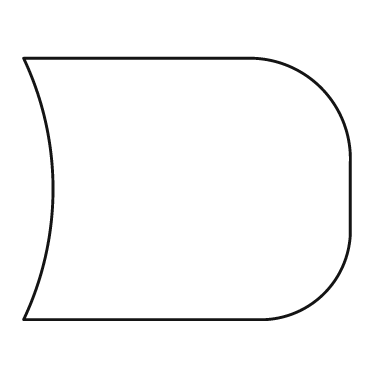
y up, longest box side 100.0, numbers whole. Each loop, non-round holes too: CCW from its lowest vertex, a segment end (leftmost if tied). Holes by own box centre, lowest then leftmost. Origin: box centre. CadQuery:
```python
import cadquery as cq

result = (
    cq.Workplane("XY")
    .moveTo(-50.0, -40.0)
    .lineTo(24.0, -40.0)
    .threePointArc((42.0, -32.0), (50.0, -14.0))
    .lineTo(50.0, 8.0)
    .threePointArc((41.0, 31.0), (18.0, 40.0))
    .lineTo(-50.0, 40.0)
    .threePointArc((-41.0, 0.0), (-50.0, -40.0))
    .close()
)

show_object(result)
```